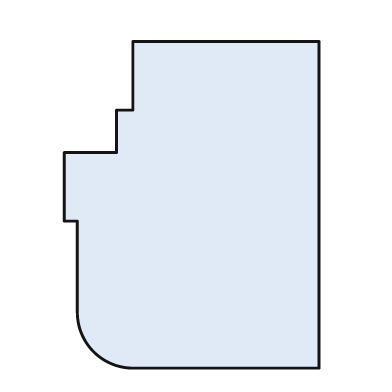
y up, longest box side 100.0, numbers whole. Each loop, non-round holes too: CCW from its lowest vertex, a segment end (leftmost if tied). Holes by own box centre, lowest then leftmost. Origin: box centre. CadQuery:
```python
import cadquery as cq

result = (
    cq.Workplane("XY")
    .moveTo(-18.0, -50.0)
    .lineTo(39.0, -50.0)
    .lineTo(39.0, 50.0)
    .lineTo(-18.0, 50.0)
    .lineTo(-18.0, 29.0)
    .lineTo(-23.0, 29.0)
    .lineTo(-23.0, 16.0)
    .lineTo(-39.0, 16.0)
    .lineTo(-39.0, -5.0)
    .lineTo(-35.0, -5.0)
    .lineTo(-35.0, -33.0)
    .threePointArc((-30.0, -45.0), (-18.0, -50.0))
    .close()
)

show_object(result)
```